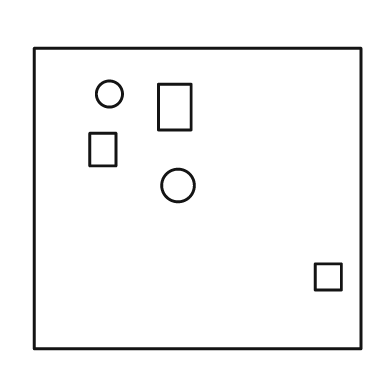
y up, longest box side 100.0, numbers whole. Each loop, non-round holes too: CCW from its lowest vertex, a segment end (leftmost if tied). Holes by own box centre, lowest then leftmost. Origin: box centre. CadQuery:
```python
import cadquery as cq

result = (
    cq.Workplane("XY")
    .moveTo(-50.0, -46.0)
    .lineTo(50.0, -46.0)
    .lineTo(50.0, 46.0)
    .lineTo(-50.0, 46.0)
    .close()
    .moveTo(36.0, -28.0)
    .lineTo(44.0, -28.0)
    .lineTo(44.0, -20.0)
    .lineTo(36.0, -20.0)
    .close()
    .moveTo(-6.0, 4.0)
    .circle(5.0)
    .moveTo(-33.0, 10.0)
    .lineTo(-25.0, 10.0)
    .lineTo(-25.0, 20.0)
    .lineTo(-33.0, 20.0)
    .close()
    .moveTo(-12.0, 21.0)
    .lineTo(-2.0, 21.0)
    .lineTo(-2.0, 35.0)
    .lineTo(-12.0, 35.0)
    .close()
    .moveTo(-27.0, 32.0)
    .circle(4.0)
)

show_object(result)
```